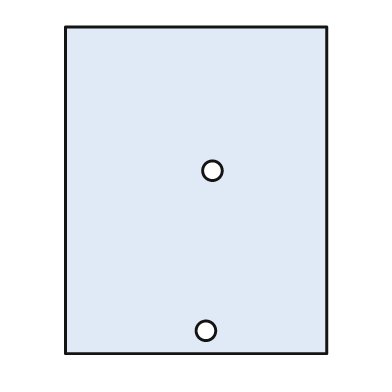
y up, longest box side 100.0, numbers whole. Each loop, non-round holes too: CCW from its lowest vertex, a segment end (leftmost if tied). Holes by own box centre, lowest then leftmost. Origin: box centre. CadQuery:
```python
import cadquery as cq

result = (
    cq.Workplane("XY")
    .moveTo(-40.0, -50.0)
    .lineTo(40.0, -50.0)
    .lineTo(40.0, 50.0)
    .lineTo(-40.0, 50.0)
    .close()
    .moveTo(3.0, -43.0)
    .circle(3.0)
    .moveTo(5.0, 6.0)
    .circle(3.0)
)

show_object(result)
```